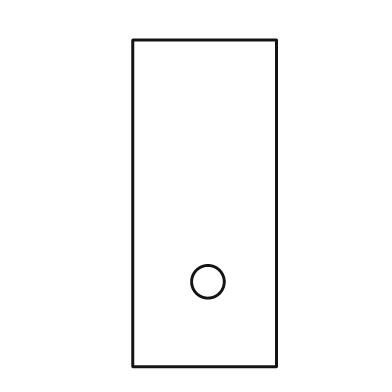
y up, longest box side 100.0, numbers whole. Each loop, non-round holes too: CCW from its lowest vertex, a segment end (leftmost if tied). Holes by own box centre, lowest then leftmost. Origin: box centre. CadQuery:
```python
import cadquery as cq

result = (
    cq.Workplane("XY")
    .moveTo(-22.0, -50.0)
    .lineTo(22.0, -50.0)
    .lineTo(22.0, 50.0)
    .lineTo(-22.0, 50.0)
    .close()
    .moveTo(1.0, -24.0)
    .circle(5.0)
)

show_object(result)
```